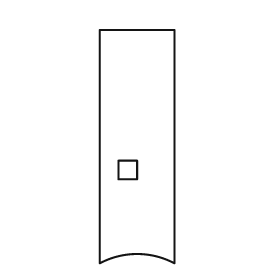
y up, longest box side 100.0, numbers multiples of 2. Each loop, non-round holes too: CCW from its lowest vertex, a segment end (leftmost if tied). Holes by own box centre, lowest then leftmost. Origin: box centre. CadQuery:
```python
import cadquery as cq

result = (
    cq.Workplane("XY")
    .moveTo(-16.0, -50.0)
    .threePointArc((0.0, -46.0), (16.0, -50.0))
    .lineTo(16.0, 50.0)
    .lineTo(-16.0, 50.0)
    .close()
    .moveTo(-8.0, -14.0)
    .lineTo(0.0, -14.0)
    .lineTo(0.0, -6.0)
    .lineTo(-8.0, -6.0)
    .close()
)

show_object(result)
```